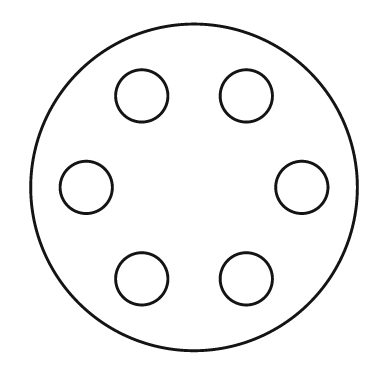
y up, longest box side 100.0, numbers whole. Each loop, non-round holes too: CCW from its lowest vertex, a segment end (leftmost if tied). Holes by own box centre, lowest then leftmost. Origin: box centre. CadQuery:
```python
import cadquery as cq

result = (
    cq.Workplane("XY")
    .moveTo(0.0, 0.0)
    .circle(50.0)
    .moveTo(-16.0, -28.0)
    .circle(8.0)
    .moveTo(16.0, -28.0)
    .circle(8.0)
    .moveTo(-33.0, 0.0)
    .circle(8.0)
    .moveTo(33.0, 0.0)
    .circle(8.0)
    .moveTo(-16.0, 28.0)
    .circle(8.0)
    .moveTo(16.0, 28.0)
    .circle(8.0)
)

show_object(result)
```